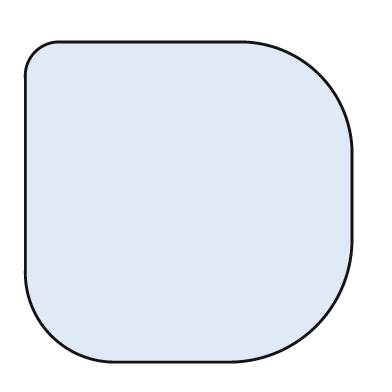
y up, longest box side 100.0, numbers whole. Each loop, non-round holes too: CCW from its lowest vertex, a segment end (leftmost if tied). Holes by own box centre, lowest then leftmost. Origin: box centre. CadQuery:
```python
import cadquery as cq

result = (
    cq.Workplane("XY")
    .moveTo(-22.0, -49.0)
    .lineTo(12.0, -49.0)
    .threePointArc((39.0, -38.0), (50.0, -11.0))
    .lineTo(50.0, 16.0)
    .threePointArc((40.0, 39.0), (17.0, 49.0))
    .lineTo(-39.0, 49.0)
    .threePointArc((-47.0, 46.0), (-50.0, 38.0))
    .lineTo(-50.0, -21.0)
    .threePointArc((-42.0, -41.0), (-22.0, -49.0))
    .close()
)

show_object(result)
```